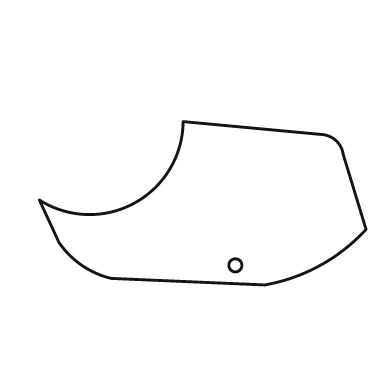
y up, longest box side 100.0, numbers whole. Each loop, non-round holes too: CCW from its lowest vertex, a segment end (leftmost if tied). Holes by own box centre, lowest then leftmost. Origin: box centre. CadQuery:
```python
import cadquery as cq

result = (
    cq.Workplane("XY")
    .moveTo(19.0, -25.0)
    .threePointArc((36.0, -19.0), (50.0, -8.0))
    .lineTo(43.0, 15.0)
    .threePointArc((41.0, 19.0), (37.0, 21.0))
    .lineTo(-6.0, 25.0)
    .threePointArc((-21.0, 0.0), (-50.0, 1.0))
    .lineTo(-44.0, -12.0)
    .threePointArc((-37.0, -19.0), (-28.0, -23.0))
    .close()
    .moveTo(10.0, -19.0)
    .circle(2.0)
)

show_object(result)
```